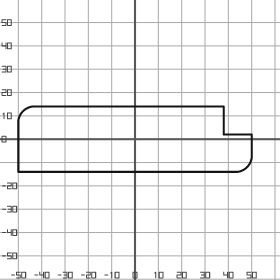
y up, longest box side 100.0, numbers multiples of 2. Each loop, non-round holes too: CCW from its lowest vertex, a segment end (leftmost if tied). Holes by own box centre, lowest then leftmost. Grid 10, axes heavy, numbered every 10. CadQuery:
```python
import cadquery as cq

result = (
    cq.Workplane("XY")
    .moveTo(-50.0, -14.0)
    .lineTo(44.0, -14.0)
    .threePointArc((48.0, -12.0), (50.0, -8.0))
    .lineTo(50.0, 2.0)
    .lineTo(38.0, 2.0)
    .lineTo(38.0, 14.0)
    .lineTo(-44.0, 14.0)
    .threePointArc((-48.0, 12.0), (-50.0, 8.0))
    .close()
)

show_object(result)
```